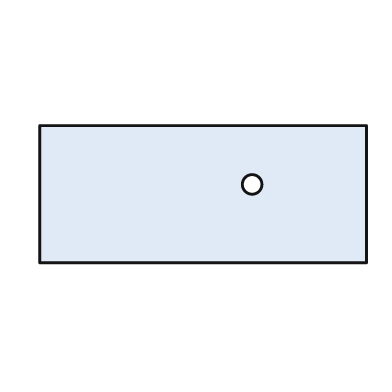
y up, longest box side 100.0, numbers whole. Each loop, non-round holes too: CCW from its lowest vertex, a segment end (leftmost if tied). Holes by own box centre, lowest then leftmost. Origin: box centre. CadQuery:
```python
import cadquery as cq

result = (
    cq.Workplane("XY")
    .moveTo(-50.0, -21.0)
    .lineTo(50.0, -21.0)
    .lineTo(50.0, 21.0)
    .lineTo(-50.0, 21.0)
    .close()
    .moveTo(15.0, 3.0)
    .circle(3.0)
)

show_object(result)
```